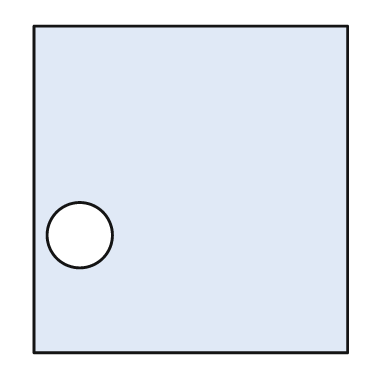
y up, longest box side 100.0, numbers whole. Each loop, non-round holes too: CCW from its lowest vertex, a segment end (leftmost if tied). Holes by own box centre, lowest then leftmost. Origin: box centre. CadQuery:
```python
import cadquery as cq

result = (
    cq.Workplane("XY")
    .moveTo(-48.0, -50.0)
    .lineTo(48.0, -50.0)
    .lineTo(48.0, 50.0)
    .lineTo(-48.0, 50.0)
    .close()
    .moveTo(-34.0, -14.0)
    .circle(10.0)
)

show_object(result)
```